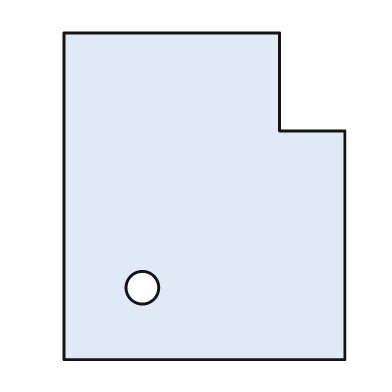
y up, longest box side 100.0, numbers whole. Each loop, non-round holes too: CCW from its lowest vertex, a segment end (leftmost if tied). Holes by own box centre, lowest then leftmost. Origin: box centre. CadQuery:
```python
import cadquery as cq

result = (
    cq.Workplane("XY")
    .moveTo(-43.0, -50.0)
    .lineTo(43.0, -50.0)
    .lineTo(43.0, 20.0)
    .lineTo(23.0, 20.0)
    .lineTo(23.0, 50.0)
    .lineTo(-43.0, 50.0)
    .close()
    .moveTo(-19.0, -28.0)
    .circle(5.0)
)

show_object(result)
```